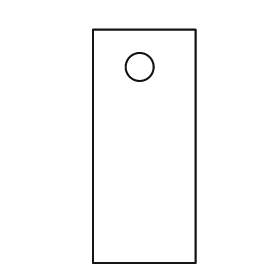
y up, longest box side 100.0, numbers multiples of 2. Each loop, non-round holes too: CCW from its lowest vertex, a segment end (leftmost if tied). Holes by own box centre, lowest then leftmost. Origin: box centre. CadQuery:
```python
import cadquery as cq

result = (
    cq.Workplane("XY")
    .moveTo(-22.0, -50.0)
    .lineTo(22.0, -50.0)
    .lineTo(22.0, 50.0)
    .lineTo(-22.0, 50.0)
    .close()
    .moveTo(-2.0, 34.0)
    .circle(6.0)
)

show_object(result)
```